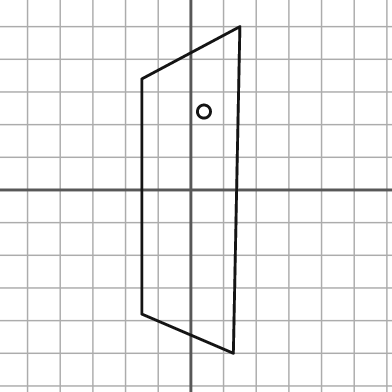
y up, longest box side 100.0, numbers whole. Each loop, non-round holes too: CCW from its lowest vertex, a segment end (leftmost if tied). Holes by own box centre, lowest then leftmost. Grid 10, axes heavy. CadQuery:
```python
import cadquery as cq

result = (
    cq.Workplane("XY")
    .moveTo(13.0, -50.0)
    .lineTo(15.0, 50.0)
    .lineTo(-15.0, 34.0)
    .lineTo(-15.0, -38.0)
    .close()
    .moveTo(4.0, 24.0)
    .circle(2.0)
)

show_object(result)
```